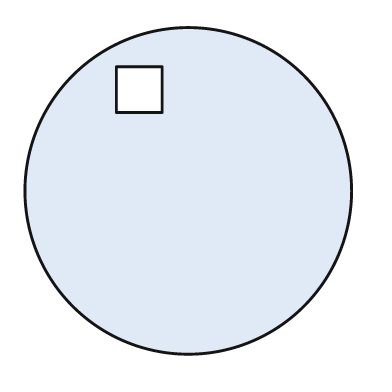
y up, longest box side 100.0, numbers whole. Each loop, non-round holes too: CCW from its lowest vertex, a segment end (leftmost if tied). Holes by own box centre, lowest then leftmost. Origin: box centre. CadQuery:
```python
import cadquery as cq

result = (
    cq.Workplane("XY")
    .moveTo(0.0, 0.0)
    .circle(50.0)
    .moveTo(-22.0, 24.0)
    .lineTo(-8.0, 24.0)
    .lineTo(-8.0, 38.0)
    .lineTo(-22.0, 38.0)
    .close()
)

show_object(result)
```